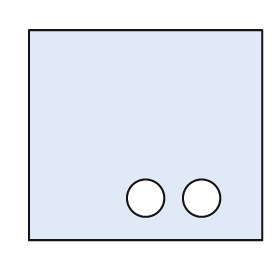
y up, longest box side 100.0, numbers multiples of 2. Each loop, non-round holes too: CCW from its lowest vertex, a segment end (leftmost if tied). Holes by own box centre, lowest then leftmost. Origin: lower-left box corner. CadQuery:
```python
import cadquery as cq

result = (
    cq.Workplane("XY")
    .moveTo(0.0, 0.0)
    .lineTo(100.0, 0.0)
    .lineTo(100.0, 90.0)
    .lineTo(0.0, 90.0)
    .close()
    .moveTo(50.0, 18.0)
    .circle(8.0)
    .moveTo(74.0, 18.0)
    .circle(8.0)
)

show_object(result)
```